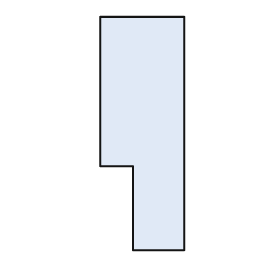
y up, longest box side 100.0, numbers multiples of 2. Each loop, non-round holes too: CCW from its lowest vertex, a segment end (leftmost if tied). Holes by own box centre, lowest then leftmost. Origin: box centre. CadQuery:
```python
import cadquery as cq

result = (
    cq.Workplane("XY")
    .moveTo(-4.0, -50.0)
    .lineTo(18.0, -50.0)
    .lineTo(18.0, 50.0)
    .lineTo(-18.0, 50.0)
    .lineTo(-18.0, -14.0)
    .lineTo(-4.0, -14.0)
    .close()
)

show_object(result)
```